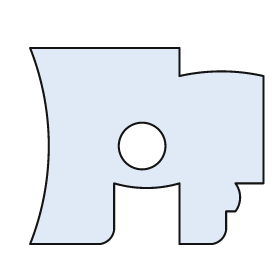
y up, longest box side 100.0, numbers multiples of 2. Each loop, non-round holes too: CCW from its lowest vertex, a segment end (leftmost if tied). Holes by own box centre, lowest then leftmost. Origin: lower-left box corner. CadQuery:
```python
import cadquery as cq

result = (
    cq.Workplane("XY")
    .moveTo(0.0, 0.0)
    .lineTo(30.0, 0.0)
    .threePointArc((34.0, 2.0), (36.0, 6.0))
    .lineTo(36.0, 26.0)
    .threePointArc((50.0, 24.0), (64.0, 26.0))
    .lineTo(64.0, 0.0)
    .lineTo(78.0, 0.0)
    .threePointArc((82.0, 2.0), (84.0, 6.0))
    .lineTo(84.0, 14.0)
    .lineTo(88.0, 14.0)
    .threePointArc((90.0, 20.0), (88.0, 26.0))
    .lineTo(100.0, 26.0)
    .lineTo(100.0, 72.0)
    .threePointArc((82.0, 74.0), (64.0, 72.0))
    .lineTo(64.0, 84.0)
    .lineTo(0.0, 84.0)
    .threePointArc((8.0, 42.0), (0.0, 0.0))
    .close()
    .moveTo(48.0, 42.0)
    .circle(10.0)
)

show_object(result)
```